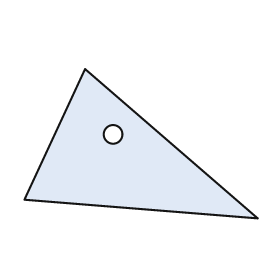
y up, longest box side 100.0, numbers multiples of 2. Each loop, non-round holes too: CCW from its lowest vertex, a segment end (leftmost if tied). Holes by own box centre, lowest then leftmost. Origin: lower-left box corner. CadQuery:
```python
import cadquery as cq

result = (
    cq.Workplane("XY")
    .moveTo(100.0, 0.0)
    .lineTo(26.0, 64.0)
    .lineTo(0.0, 8.0)
    .close()
    .moveTo(38.0, 36.0)
    .circle(4.0)
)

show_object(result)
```